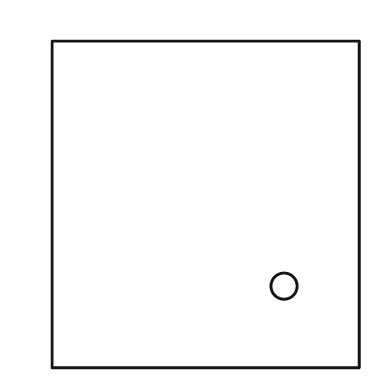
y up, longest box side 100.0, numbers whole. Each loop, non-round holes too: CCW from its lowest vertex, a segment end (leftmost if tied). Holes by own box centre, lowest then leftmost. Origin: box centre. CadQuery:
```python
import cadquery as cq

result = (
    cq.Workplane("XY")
    .moveTo(-47.0, -50.0)
    .lineTo(47.0, -50.0)
    .lineTo(47.0, 50.0)
    .lineTo(-47.0, 50.0)
    .close()
    .moveTo(24.0, -25.0)
    .circle(4.0)
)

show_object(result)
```